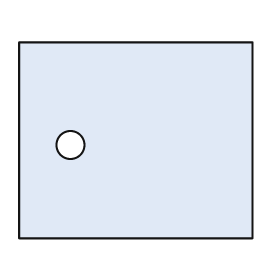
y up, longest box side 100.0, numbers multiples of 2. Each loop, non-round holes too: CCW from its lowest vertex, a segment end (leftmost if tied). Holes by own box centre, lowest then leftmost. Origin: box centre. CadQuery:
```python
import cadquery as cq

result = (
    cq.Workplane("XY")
    .moveTo(-50.0, -42.0)
    .lineTo(50.0, -42.0)
    .lineTo(50.0, 42.0)
    .lineTo(-50.0, 42.0)
    .close()
    .moveTo(-28.0, -2.0)
    .circle(6.0)
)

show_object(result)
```